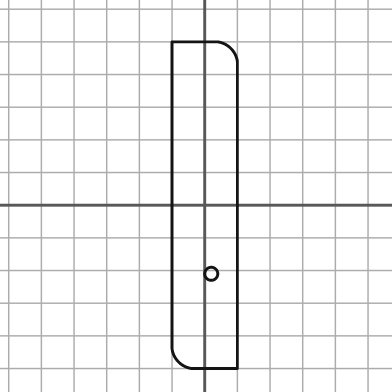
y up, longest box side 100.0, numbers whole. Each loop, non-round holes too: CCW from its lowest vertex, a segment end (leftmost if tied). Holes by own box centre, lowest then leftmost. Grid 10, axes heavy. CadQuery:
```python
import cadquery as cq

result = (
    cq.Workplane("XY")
    .moveTo(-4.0, -50.0)
    .lineTo(10.0, -50.0)
    .lineTo(10.0, 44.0)
    .threePointArc((8.0, 48.0), (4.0, 50.0))
    .lineTo(-10.0, 50.0)
    .lineTo(-10.0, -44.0)
    .threePointArc((-8.0, -48.0), (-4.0, -50.0))
    .close()
    .moveTo(2.0, -21.0)
    .circle(2.0)
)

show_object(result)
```